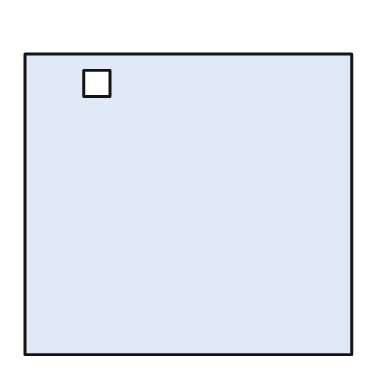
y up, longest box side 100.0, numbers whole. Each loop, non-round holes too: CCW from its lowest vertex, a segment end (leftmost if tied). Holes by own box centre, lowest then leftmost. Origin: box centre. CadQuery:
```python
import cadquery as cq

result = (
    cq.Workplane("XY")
    .moveTo(-50.0, -46.0)
    .lineTo(50.0, -46.0)
    .lineTo(50.0, 46.0)
    .lineTo(-50.0, 46.0)
    .close()
    .moveTo(-32.0, 33.0)
    .lineTo(-24.0, 33.0)
    .lineTo(-24.0, 41.0)
    .lineTo(-32.0, 41.0)
    .close()
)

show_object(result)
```